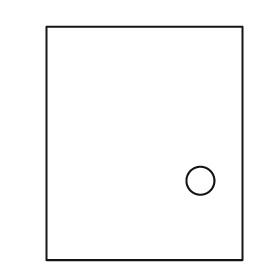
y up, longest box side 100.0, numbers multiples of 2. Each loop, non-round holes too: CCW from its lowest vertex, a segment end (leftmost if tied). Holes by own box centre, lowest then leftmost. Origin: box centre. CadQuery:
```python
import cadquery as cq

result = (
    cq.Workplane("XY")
    .moveTo(-42.0, -50.0)
    .lineTo(42.0, -50.0)
    .lineTo(42.0, 50.0)
    .lineTo(-42.0, 50.0)
    .close()
    .moveTo(24.0, -16.0)
    .circle(6.0)
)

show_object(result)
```